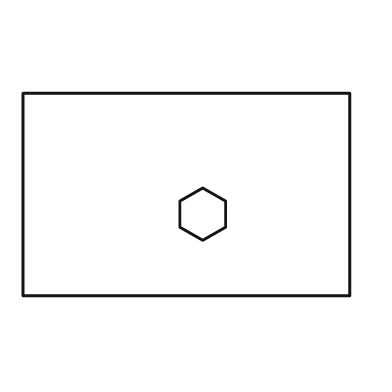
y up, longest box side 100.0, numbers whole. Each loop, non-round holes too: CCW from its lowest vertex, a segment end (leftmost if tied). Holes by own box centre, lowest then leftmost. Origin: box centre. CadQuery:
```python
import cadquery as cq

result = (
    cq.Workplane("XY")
    .moveTo(-50.0, -31.0)
    .lineTo(50.0, -31.0)
    .lineTo(50.0, 31.0)
    .lineTo(-50.0, 31.0)
    .close()
    .moveTo(5.0, -14.0)
    .lineTo(12.0, -10.0)
    .lineTo(12.0, -2.0)
    .lineTo(5.0, 2.0)
    .lineTo(-2.0, -2.0)
    .lineTo(-2.0, -10.0)
    .close()
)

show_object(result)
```